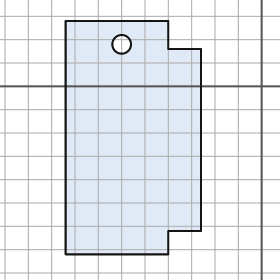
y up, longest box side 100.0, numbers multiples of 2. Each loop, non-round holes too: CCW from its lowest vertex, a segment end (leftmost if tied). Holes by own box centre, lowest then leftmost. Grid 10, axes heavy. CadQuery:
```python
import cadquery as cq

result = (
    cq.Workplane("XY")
    .moveTo(-84.0, -72.0)
    .lineTo(-40.0, -72.0)
    .lineTo(-40.0, -62.0)
    .lineTo(-26.0, -62.0)
    .lineTo(-26.0, 16.0)
    .lineTo(-40.0, 16.0)
    .lineTo(-40.0, 28.0)
    .lineTo(-84.0, 28.0)
    .close()
    .moveTo(-60.0, 18.0)
    .circle(4.0)
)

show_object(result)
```